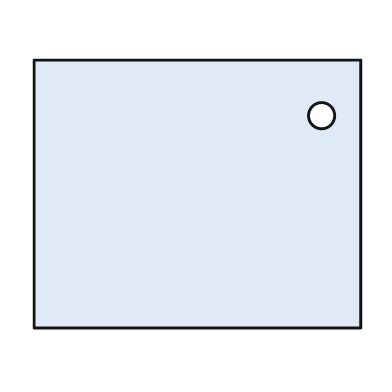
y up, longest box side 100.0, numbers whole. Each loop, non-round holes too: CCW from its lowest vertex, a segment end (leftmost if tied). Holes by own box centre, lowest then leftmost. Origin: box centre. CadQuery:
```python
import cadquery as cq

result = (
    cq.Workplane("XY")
    .moveTo(-50.0, -41.0)
    .lineTo(50.0, -41.0)
    .lineTo(50.0, 41.0)
    .lineTo(-50.0, 41.0)
    .close()
    .moveTo(38.0, 24.0)
    .circle(4.0)
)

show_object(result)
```